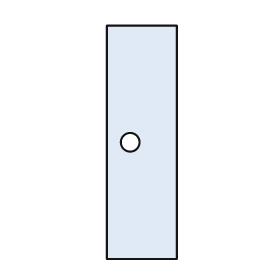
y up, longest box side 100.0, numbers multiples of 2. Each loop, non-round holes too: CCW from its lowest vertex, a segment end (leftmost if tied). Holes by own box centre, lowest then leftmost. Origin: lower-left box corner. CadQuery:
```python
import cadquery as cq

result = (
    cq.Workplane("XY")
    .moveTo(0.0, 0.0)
    .lineTo(30.0, 0.0)
    .lineTo(30.0, 100.0)
    .lineTo(0.0, 100.0)
    .close()
    .moveTo(10.0, 50.0)
    .circle(4.0)
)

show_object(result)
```